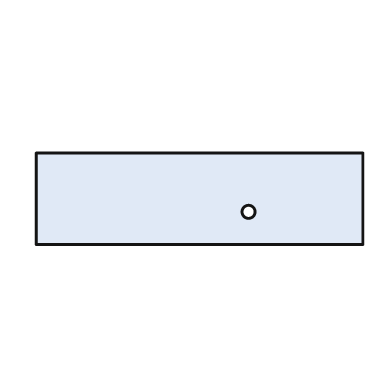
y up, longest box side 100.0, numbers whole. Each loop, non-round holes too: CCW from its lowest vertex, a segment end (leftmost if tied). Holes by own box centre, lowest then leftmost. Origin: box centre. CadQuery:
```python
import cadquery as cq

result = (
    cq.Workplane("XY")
    .moveTo(-50.0, -14.0)
    .lineTo(50.0, -14.0)
    .lineTo(50.0, 14.0)
    .lineTo(-50.0, 14.0)
    .close()
    .moveTo(15.0, -4.0)
    .circle(2.0)
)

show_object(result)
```